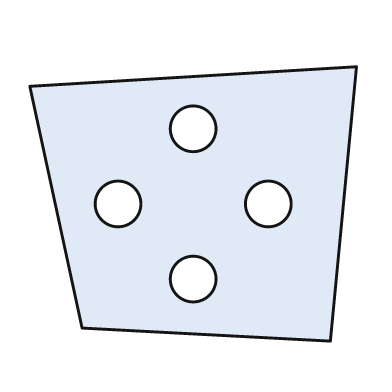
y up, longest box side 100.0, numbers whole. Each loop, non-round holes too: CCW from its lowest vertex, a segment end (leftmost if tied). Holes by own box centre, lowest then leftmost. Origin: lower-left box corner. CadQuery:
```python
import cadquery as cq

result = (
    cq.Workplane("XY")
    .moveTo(92.0, 0.0)
    .lineTo(100.0, 84.0)
    .lineTo(0.0, 78.0)
    .lineTo(16.0, 4.0)
    .close()
    .moveTo(50.0, 19.0)
    .circle(7.0)
    .moveTo(27.0, 42.0)
    .circle(7.0)
    .moveTo(73.0, 42.0)
    .circle(7.0)
    .moveTo(50.0, 65.0)
    .circle(7.0)
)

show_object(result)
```